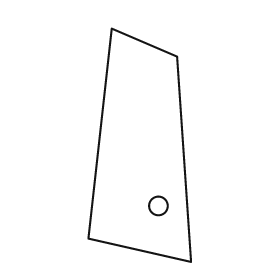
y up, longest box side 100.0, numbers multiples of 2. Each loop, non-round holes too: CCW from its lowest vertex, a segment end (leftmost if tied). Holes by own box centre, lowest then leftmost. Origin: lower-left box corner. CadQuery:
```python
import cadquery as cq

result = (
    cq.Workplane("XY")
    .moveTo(44.0, 0.0)
    .lineTo(38.0, 88.0)
    .lineTo(10.0, 100.0)
    .lineTo(0.0, 10.0)
    .close()
    .moveTo(30.0, 24.0)
    .circle(4.0)
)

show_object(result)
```